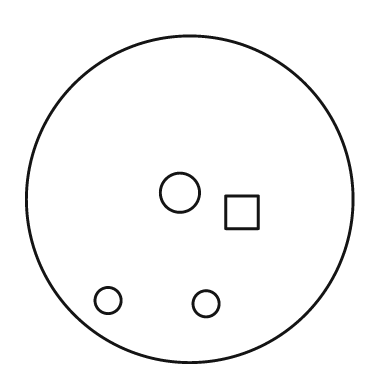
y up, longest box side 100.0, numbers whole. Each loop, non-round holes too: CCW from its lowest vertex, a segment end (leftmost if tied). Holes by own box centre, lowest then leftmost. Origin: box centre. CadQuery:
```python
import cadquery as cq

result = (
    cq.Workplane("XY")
    .moveTo(0.0, 0.0)
    .circle(50.0)
    .moveTo(5.0, -32.0)
    .circle(4.0)
    .moveTo(-25.0, -31.0)
    .circle(4.0)
    .moveTo(11.0, -9.0)
    .lineTo(21.0, -9.0)
    .lineTo(21.0, 1.0)
    .lineTo(11.0, 1.0)
    .close()
    .moveTo(-3.0, 2.0)
    .circle(6.0)
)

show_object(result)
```